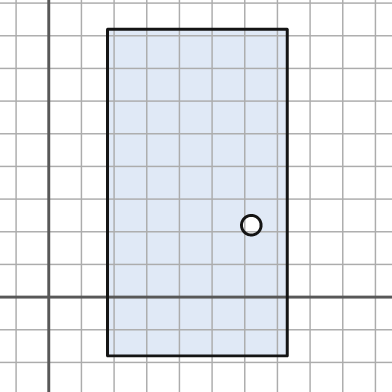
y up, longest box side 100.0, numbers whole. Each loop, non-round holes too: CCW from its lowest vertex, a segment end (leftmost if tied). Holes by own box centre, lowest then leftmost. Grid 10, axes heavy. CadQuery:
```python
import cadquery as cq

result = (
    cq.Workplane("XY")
    .moveTo(18.0, -18.0)
    .lineTo(73.0, -18.0)
    .lineTo(73.0, 82.0)
    .lineTo(18.0, 82.0)
    .close()
    .moveTo(62.0, 22.0)
    .circle(3.0)
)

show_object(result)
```